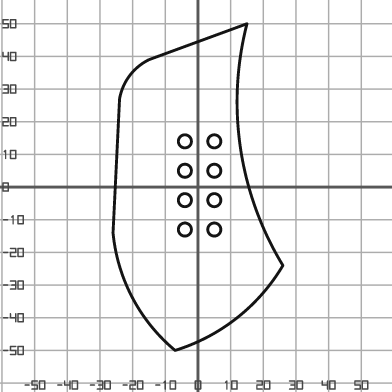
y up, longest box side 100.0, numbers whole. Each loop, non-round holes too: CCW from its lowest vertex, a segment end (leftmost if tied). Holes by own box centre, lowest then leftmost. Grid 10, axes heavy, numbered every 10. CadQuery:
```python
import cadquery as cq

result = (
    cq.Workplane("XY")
    .moveTo(-7.0, -50.0)
    .threePointArc((12.0, -40.0), (26.0, -24.0))
    .threePointArc((13.0, 12.0), (15.0, 50.0))
    .lineTo(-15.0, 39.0)
    .threePointArc((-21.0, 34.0), (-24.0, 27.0))
    .lineTo(-26.0, -14.0)
    .threePointArc((-20.0, -34.0), (-7.0, -50.0))
    .close()
    .moveTo(-4.0, -13.0)
    .circle(2.0)
    .moveTo(5.0, -13.0)
    .circle(2.0)
    .moveTo(-4.0, -4.0)
    .circle(2.0)
    .moveTo(5.0, -4.0)
    .circle(2.0)
    .moveTo(-4.0, 5.0)
    .circle(2.0)
    .moveTo(5.0, 5.0)
    .circle(2.0)
    .moveTo(-4.0, 14.0)
    .circle(2.0)
    .moveTo(5.0, 14.0)
    .circle(2.0)
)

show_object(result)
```